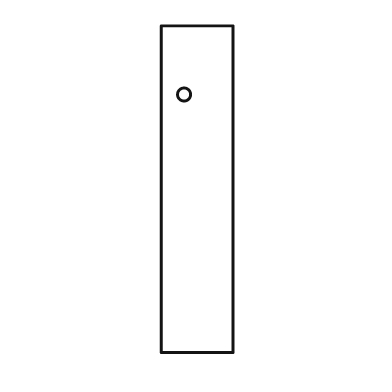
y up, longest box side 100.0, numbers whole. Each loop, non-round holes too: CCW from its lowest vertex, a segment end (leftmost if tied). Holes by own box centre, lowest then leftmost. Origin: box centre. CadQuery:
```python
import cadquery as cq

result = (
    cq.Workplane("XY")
    .moveTo(-11.0, -50.0)
    .lineTo(11.0, -50.0)
    .lineTo(11.0, 50.0)
    .lineTo(-11.0, 50.0)
    .close()
    .moveTo(-4.0, 29.0)
    .circle(2.0)
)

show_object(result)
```